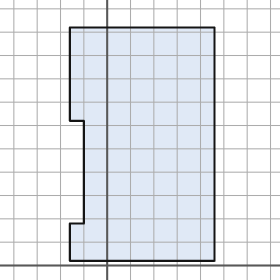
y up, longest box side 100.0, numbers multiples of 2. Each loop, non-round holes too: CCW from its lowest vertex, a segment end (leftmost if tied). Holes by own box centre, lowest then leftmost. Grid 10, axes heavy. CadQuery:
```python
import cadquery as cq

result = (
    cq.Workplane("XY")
    .moveTo(-16.0, 2.0)
    .lineTo(46.0, 2.0)
    .lineTo(46.0, 102.0)
    .lineTo(-16.0, 102.0)
    .lineTo(-16.0, 62.0)
    .lineTo(-10.0, 62.0)
    .lineTo(-10.0, 18.0)
    .lineTo(-16.0, 18.0)
    .close()
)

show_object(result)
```